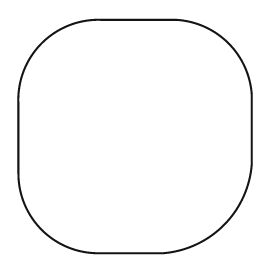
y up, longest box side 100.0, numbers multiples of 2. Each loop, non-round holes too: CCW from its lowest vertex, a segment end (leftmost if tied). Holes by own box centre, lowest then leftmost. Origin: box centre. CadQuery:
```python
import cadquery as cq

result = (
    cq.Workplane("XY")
    .moveTo(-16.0, -50.0)
    .lineTo(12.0, -50.0)
    .threePointArc((38.0, -38.0), (50.0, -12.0))
    .lineTo(50.0, 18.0)
    .threePointArc((40.0, 40.0), (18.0, 50.0))
    .lineTo(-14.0, 50.0)
    .threePointArc((-40.0, 40.0), (-50.0, 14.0))
    .lineTo(-50.0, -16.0)
    .threePointArc((-40.0, -40.0), (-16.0, -50.0))
    .close()
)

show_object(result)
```